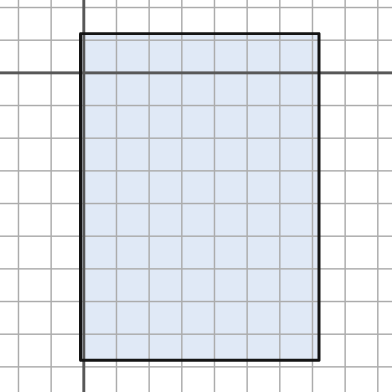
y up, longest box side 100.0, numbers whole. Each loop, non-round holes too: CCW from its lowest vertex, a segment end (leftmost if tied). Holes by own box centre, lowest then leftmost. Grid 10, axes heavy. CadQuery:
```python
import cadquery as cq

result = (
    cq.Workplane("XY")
    .moveTo(-1.0, -88.0)
    .lineTo(72.0, -88.0)
    .lineTo(72.0, 12.0)
    .lineTo(-1.0, 12.0)
    .close()
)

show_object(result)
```